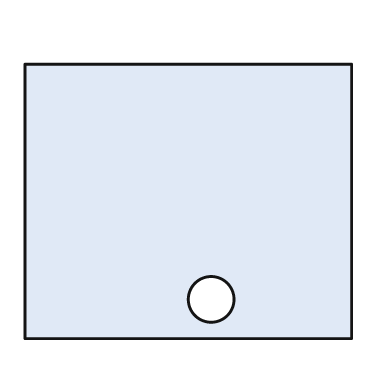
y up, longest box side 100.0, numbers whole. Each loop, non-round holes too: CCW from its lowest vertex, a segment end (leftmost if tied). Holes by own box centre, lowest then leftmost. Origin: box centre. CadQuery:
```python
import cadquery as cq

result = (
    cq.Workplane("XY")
    .moveTo(-50.0, -42.0)
    .lineTo(50.0, -42.0)
    .lineTo(50.0, 42.0)
    .lineTo(-50.0, 42.0)
    .close()
    .moveTo(7.0, -30.0)
    .circle(7.0)
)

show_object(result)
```